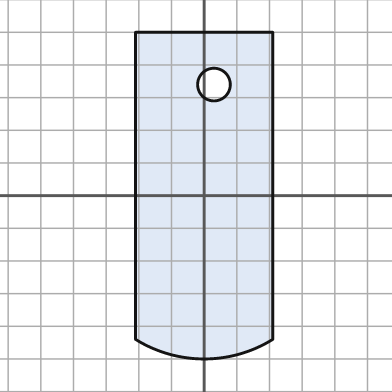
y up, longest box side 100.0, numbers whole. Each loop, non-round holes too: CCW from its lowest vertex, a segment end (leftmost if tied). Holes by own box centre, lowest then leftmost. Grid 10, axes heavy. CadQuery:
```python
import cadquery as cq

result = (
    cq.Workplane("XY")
    .moveTo(-21.0, -44.0)
    .threePointArc((0.0, -50.0), (21.0, -44.0))
    .lineTo(21.0, 50.0)
    .lineTo(-21.0, 50.0)
    .close()
    .moveTo(3.0, 34.0)
    .circle(5.0)
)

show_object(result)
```